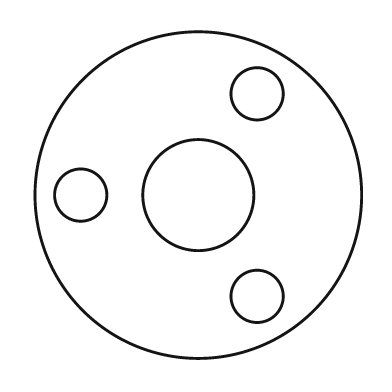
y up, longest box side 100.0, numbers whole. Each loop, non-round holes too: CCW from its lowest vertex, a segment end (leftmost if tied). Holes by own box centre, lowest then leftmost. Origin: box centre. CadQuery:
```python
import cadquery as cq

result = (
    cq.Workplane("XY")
    .moveTo(0.0, 0.0)
    .circle(50.0)
    .moveTo(18.0, -31.0)
    .circle(8.0)
    .moveTo(-36.0, 0.0)
    .circle(8.0)
    .moveTo(0.0, 0.0)
    .circle(17.0)
    .moveTo(18.0, 31.0)
    .circle(8.0)
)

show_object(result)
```